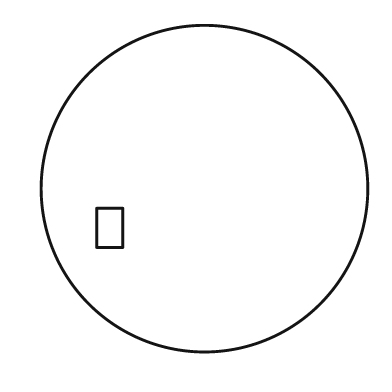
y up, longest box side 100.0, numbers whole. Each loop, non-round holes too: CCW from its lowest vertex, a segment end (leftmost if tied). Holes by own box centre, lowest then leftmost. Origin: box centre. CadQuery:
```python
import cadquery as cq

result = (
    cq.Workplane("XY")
    .moveTo(0.0, 0.0)
    .circle(50.0)
    .moveTo(-33.0, -18.0)
    .lineTo(-25.0, -18.0)
    .lineTo(-25.0, -6.0)
    .lineTo(-33.0, -6.0)
    .close()
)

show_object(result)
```